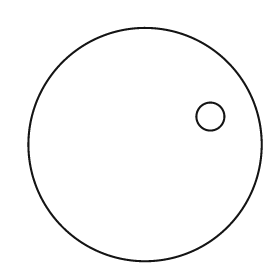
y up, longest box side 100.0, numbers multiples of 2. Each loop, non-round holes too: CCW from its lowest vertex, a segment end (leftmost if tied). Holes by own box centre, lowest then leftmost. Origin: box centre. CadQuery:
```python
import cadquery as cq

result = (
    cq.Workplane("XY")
    .moveTo(0.0, 0.0)
    .circle(50.0)
    .moveTo(28.0, 12.0)
    .circle(6.0)
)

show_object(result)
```